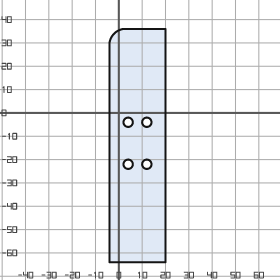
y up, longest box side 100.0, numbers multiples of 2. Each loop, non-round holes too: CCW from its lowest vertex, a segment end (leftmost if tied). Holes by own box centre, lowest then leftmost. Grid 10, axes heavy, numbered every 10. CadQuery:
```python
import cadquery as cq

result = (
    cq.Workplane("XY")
    .moveTo(-4.0, -64.0)
    .lineTo(20.0, -64.0)
    .lineTo(20.0, 36.0)
    .lineTo(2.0, 36.0)
    .threePointArc((-2.0, 34.0), (-4.0, 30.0))
    .close()
    .moveTo(4.0, -22.0)
    .circle(2.0)
    .moveTo(12.0, -22.0)
    .circle(2.0)
    .moveTo(4.0, -4.0)
    .circle(2.0)
    .moveTo(12.0, -4.0)
    .circle(2.0)
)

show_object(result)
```